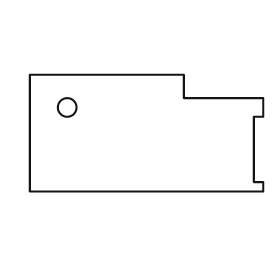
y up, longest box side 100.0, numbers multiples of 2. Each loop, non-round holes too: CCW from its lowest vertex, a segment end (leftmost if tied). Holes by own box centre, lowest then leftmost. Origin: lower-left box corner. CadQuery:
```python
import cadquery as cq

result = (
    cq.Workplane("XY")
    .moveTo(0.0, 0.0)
    .lineTo(100.0, 0.0)
    .lineTo(100.0, 4.0)
    .lineTo(96.0, 4.0)
    .lineTo(96.0, 32.0)
    .lineTo(100.0, 32.0)
    .lineTo(100.0, 40.0)
    .lineTo(66.0, 40.0)
    .lineTo(66.0, 50.0)
    .lineTo(0.0, 50.0)
    .close()
    .moveTo(16.0, 36.0)
    .circle(4.0)
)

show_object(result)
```